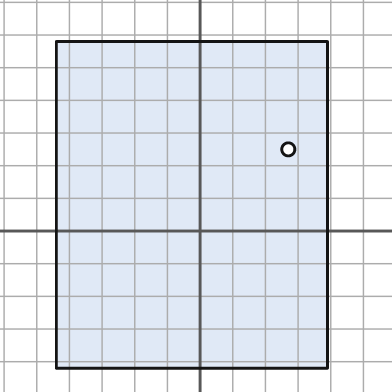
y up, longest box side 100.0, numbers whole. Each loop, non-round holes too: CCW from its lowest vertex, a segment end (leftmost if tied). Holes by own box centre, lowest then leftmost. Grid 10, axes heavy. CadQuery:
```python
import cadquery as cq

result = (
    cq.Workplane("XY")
    .moveTo(-44.0, -42.0)
    .lineTo(39.0, -42.0)
    .lineTo(39.0, 58.0)
    .lineTo(-44.0, 58.0)
    .close()
    .moveTo(27.0, 25.0)
    .circle(2.0)
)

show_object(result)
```